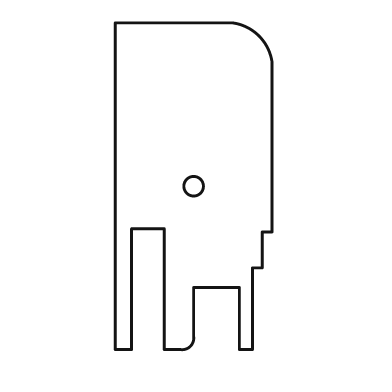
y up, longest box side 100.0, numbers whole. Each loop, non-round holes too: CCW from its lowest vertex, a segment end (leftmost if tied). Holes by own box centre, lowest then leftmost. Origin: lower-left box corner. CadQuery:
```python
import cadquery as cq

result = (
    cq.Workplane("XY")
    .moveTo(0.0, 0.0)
    .lineTo(5.0, 0.0)
    .lineTo(5.0, 37.0)
    .lineTo(15.0, 37.0)
    .lineTo(15.0, 0.0)
    .lineTo(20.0, 0.0)
    .threePointArc((23.0, 1.0), (24.0, 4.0))
    .lineTo(24.0, 19.0)
    .lineTo(38.0, 19.0)
    .lineTo(38.0, 0.0)
    .lineTo(42.0, 0.0)
    .lineTo(42.0, 25.0)
    .lineTo(45.0, 25.0)
    .lineTo(45.0, 36.0)
    .lineTo(48.0, 36.0)
    .lineTo(48.0, 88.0)
    .threePointArc((44.0, 96.0), (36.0, 100.0))
    .lineTo(0.0, 100.0)
    .close()
    .moveTo(24.0, 50.0)
    .circle(3.0)
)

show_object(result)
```